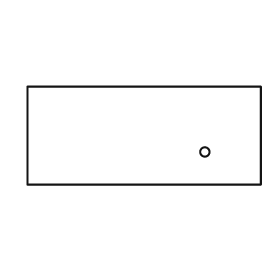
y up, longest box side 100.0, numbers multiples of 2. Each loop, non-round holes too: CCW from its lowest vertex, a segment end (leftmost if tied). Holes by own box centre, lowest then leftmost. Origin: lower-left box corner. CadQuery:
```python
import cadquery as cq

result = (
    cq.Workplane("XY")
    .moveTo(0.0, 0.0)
    .lineTo(100.0, 0.0)
    .lineTo(100.0, 42.0)
    .lineTo(0.0, 42.0)
    .close()
    .moveTo(76.0, 14.0)
    .circle(2.0)
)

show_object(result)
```